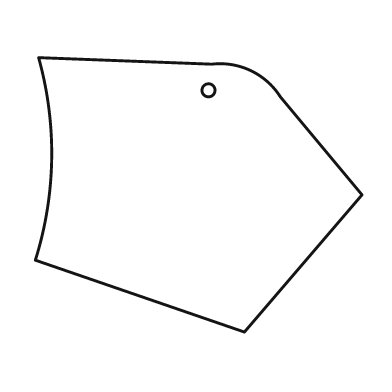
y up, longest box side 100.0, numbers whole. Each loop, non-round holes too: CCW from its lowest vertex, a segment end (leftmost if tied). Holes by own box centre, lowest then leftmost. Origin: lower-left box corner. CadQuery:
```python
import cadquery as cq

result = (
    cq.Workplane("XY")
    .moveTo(64.0, 0.0)
    .lineTo(100.0, 42.0)
    .lineTo(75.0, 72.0)
    .threePointArc((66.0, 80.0), (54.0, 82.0))
    .lineTo(1.0, 84.0)
    .threePointArc((5.0, 53.0), (0.0, 22.0))
    .close()
    .moveTo(53.0, 74.0)
    .circle(2.0)
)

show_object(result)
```